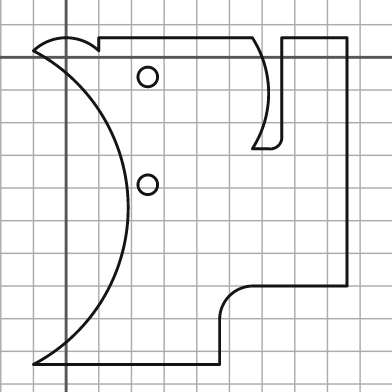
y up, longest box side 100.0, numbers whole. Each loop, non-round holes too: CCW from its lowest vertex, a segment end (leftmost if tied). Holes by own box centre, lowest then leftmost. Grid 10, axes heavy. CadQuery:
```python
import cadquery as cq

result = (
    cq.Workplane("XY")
    .moveTo(-10.0, -94.0)
    .lineTo(47.0, -94.0)
    .lineTo(47.0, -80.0)
    .threePointArc((50.0, -73.0), (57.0, -70.0))
    .lineTo(86.0, -70.0)
    .lineTo(86.0, 6.0)
    .lineTo(66.0, 6.0)
    .lineTo(66.0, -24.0)
    .threePointArc((65.0, -27.0), (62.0, -28.0))
    .lineTo(57.0, -28.0)
    .threePointArc((62.0, -11.0), (57.0, 6.0))
    .lineTo(10.0, 6.0)
    .lineTo(10.0, 2.0)
    .threePointArc((0.0, 6.0), (-10.0, 2.0))
    .threePointArc((19.0, -46.0), (-10.0, -94.0))
    .close()
    .moveTo(25.0, -39.0)
    .circle(3.0)
    .moveTo(25.0, -6.0)
    .circle(3.0)
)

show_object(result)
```